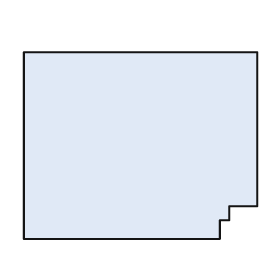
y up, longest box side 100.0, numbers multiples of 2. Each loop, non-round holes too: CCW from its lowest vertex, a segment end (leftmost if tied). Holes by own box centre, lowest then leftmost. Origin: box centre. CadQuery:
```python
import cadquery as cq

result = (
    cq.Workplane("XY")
    .moveTo(-50.0, -40.0)
    .lineTo(34.0, -40.0)
    .lineTo(34.0, -32.0)
    .lineTo(38.0, -32.0)
    .lineTo(38.0, -26.0)
    .lineTo(50.0, -26.0)
    .lineTo(50.0, 40.0)
    .lineTo(-50.0, 40.0)
    .close()
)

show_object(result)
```